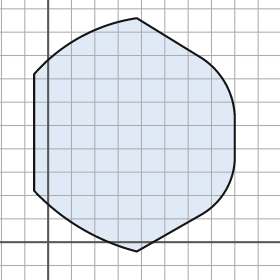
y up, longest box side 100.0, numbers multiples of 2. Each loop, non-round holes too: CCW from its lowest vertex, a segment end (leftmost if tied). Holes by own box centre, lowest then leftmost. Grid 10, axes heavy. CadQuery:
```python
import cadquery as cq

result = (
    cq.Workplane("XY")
    .moveTo(38.0, -4.0)
    .lineTo(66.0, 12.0)
    .threePointArc((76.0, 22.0), (80.0, 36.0))
    .lineTo(80.0, 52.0)
    .threePointArc((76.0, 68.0), (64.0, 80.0))
    .lineTo(38.0, 96.0)
    .threePointArc((14.0, 88.0), (-6.0, 72.0))
    .lineTo(-6.0, 22.0)
    .threePointArc((14.0, 6.0), (38.0, -4.0))
    .close()
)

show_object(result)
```